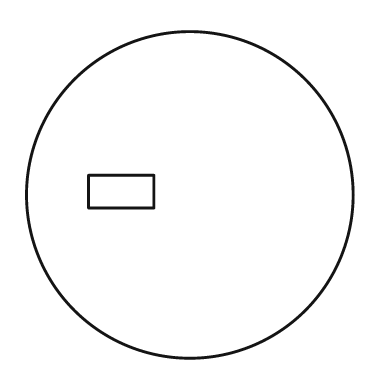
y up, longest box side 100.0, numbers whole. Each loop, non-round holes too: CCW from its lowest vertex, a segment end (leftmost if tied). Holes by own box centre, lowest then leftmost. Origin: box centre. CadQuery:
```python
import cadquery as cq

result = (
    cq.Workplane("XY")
    .moveTo(0.0, 0.0)
    .circle(50.0)
    .moveTo(-31.0, -4.0)
    .lineTo(-11.0, -4.0)
    .lineTo(-11.0, 6.0)
    .lineTo(-31.0, 6.0)
    .close()
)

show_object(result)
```